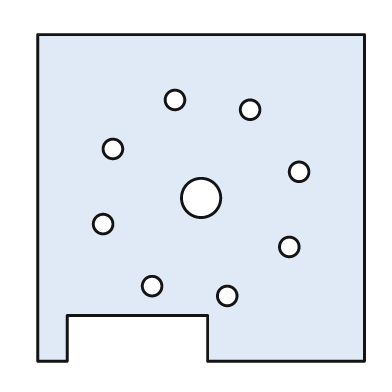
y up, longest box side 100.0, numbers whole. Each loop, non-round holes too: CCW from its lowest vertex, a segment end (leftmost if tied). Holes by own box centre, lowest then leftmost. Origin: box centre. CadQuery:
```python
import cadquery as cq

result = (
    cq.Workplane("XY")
    .moveTo(-50.0, -50.0)
    .lineTo(-41.0, -50.0)
    .lineTo(-41.0, -36.0)
    .lineTo(2.0, -36.0)
    .lineTo(2.0, -50.0)
    .lineTo(50.0, -50.0)
    .lineTo(50.0, 50.0)
    .lineTo(-50.0, 50.0)
    .close()
    .moveTo(8.0, -30.0)
    .circle(3.0)
    .moveTo(-15.0, -27.0)
    .circle(3.0)
    .moveTo(27.0, -15.0)
    .circle(3.0)
    .moveTo(-30.0, -8.0)
    .circle(3.0)
    .moveTo(0.0, 0.0)
    .circle(6.0)
    .moveTo(30.0, 8.0)
    .circle(3.0)
    .moveTo(-27.0, 15.0)
    .circle(3.0)
    .moveTo(15.0, 27.0)
    .circle(3.0)
    .moveTo(-8.0, 30.0)
    .circle(3.0)
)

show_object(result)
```